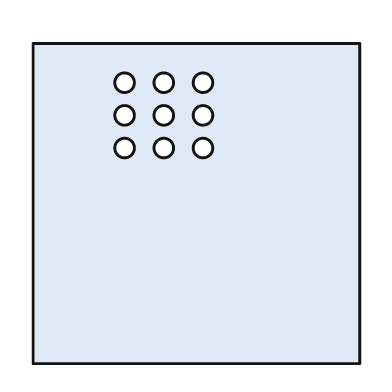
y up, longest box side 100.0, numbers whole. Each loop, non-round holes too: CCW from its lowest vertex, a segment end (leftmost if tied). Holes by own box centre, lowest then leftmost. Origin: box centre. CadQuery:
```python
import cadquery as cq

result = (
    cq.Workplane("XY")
    .moveTo(-50.0, -49.0)
    .lineTo(50.0, -49.0)
    .lineTo(50.0, 49.0)
    .lineTo(-50.0, 49.0)
    .close()
    .moveTo(-22.0, 17.0)
    .circle(3.0)
    .moveTo(-10.0, 17.0)
    .circle(3.0)
    .moveTo(2.0, 17.0)
    .circle(3.0)
    .moveTo(-22.0, 27.0)
    .circle(3.0)
    .moveTo(-10.0, 27.0)
    .circle(3.0)
    .moveTo(2.0, 27.0)
    .circle(3.0)
    .moveTo(-22.0, 37.0)
    .circle(3.0)
    .moveTo(-10.0, 37.0)
    .circle(3.0)
    .moveTo(2.0, 37.0)
    .circle(3.0)
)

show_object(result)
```